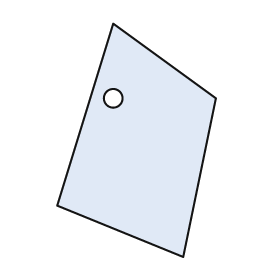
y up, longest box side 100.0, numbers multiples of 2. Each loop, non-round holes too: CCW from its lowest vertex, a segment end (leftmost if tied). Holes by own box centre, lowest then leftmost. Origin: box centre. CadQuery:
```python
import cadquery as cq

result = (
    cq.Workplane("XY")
    .moveTo(20.0, -50.0)
    .lineTo(34.0, 18.0)
    .lineTo(-10.0, 50.0)
    .lineTo(-34.0, -28.0)
    .close()
    .moveTo(-10.0, 18.0)
    .circle(4.0)
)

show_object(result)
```